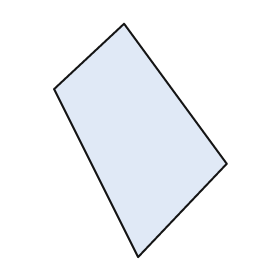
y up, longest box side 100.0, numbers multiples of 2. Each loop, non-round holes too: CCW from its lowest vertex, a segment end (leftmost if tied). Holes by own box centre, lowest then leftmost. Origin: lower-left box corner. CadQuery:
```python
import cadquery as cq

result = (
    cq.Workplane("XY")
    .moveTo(36.0, 0.0)
    .lineTo(74.0, 40.0)
    .lineTo(30.0, 100.0)
    .lineTo(0.0, 72.0)
    .close()
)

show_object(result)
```